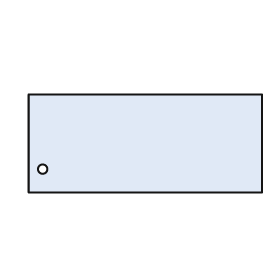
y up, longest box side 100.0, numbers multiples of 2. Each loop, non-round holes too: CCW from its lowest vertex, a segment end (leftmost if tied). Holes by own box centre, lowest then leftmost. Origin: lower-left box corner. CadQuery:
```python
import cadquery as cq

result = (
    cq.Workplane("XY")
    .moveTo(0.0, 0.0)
    .lineTo(100.0, 0.0)
    .lineTo(100.0, 42.0)
    .lineTo(0.0, 42.0)
    .close()
    .moveTo(6.0, 10.0)
    .circle(2.0)
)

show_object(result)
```